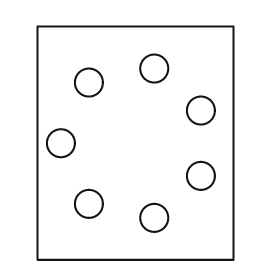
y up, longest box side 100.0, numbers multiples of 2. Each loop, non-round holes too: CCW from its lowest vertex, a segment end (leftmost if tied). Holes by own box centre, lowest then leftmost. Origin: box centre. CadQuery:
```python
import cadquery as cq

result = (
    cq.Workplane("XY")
    .moveTo(-42.0, -50.0)
    .lineTo(42.0, -50.0)
    .lineTo(42.0, 50.0)
    .lineTo(-42.0, 50.0)
    .close()
    .moveTo(8.0, -32.0)
    .circle(6.0)
    .moveTo(-20.0, -26.0)
    .circle(6.0)
    .moveTo(28.0, -14.0)
    .circle(6.0)
    .moveTo(-32.0, 0.0)
    .circle(6.0)
    .moveTo(28.0, 14.0)
    .circle(6.0)
    .moveTo(-20.0, 26.0)
    .circle(6.0)
    .moveTo(8.0, 32.0)
    .circle(6.0)
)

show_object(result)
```